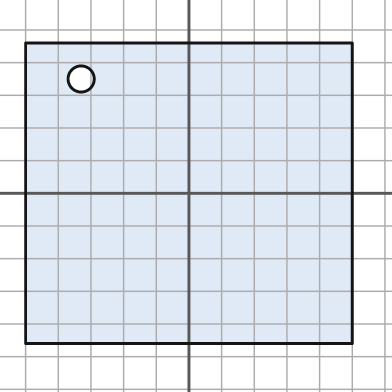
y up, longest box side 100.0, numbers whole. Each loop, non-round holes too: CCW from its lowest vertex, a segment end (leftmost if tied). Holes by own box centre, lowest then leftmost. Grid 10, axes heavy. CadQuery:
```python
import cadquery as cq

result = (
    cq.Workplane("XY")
    .moveTo(-50.0, -46.0)
    .lineTo(50.0, -46.0)
    .lineTo(50.0, 46.0)
    .lineTo(-50.0, 46.0)
    .close()
    .moveTo(-33.0, 35.0)
    .circle(4.0)
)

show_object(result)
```